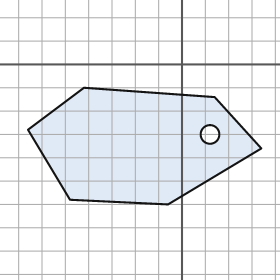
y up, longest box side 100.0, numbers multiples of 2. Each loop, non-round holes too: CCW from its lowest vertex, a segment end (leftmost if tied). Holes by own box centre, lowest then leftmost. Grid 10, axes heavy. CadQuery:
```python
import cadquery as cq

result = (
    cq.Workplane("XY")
    .moveTo(-6.0, -60.0)
    .lineTo(34.0, -36.0)
    .lineTo(14.0, -14.0)
    .lineTo(-42.0, -10.0)
    .lineTo(-66.0, -28.0)
    .lineTo(-48.0, -58.0)
    .close()
    .moveTo(12.0, -30.0)
    .circle(4.0)
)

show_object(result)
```